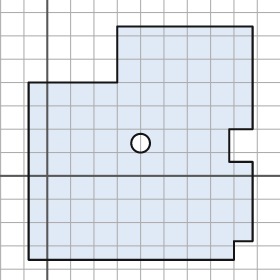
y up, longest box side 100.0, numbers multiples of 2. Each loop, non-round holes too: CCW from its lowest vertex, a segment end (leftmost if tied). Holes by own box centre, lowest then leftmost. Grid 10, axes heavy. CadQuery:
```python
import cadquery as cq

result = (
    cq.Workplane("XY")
    .moveTo(-8.0, -36.0)
    .lineTo(80.0, -36.0)
    .lineTo(80.0, -28.0)
    .lineTo(88.0, -28.0)
    .lineTo(88.0, 6.0)
    .lineTo(78.0, 6.0)
    .lineTo(78.0, 20.0)
    .lineTo(88.0, 20.0)
    .lineTo(88.0, 64.0)
    .lineTo(30.0, 64.0)
    .lineTo(30.0, 40.0)
    .lineTo(-8.0, 40.0)
    .close()
    .moveTo(40.0, 14.0)
    .circle(4.0)
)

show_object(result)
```